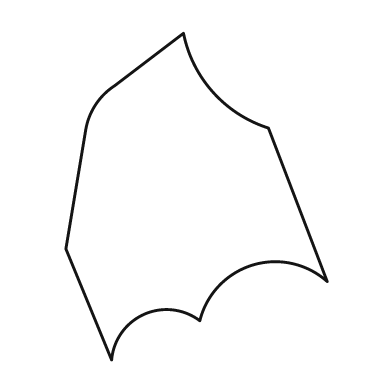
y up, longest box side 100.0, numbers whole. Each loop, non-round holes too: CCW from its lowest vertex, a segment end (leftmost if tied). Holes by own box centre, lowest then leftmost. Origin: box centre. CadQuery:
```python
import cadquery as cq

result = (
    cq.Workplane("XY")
    .moveTo(-26.0, -50.0)
    .threePointArc((-16.0, -36.0), (1.0, -38.0))
    .threePointArc((17.0, -21.0), (40.0, -26.0))
    .lineTo(22.0, 21.0)
    .threePointArc((5.0, 32.0), (-4.0, 50.0))
    .lineTo(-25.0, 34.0)
    .threePointArc((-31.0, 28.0), (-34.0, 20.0))
    .lineTo(-40.0, -16.0)
    .close()
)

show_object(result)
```